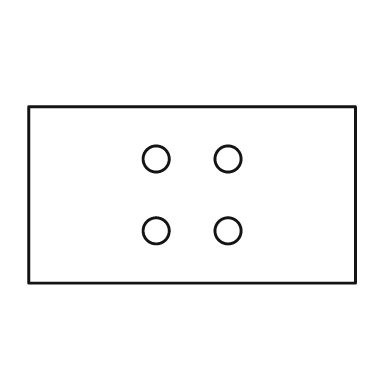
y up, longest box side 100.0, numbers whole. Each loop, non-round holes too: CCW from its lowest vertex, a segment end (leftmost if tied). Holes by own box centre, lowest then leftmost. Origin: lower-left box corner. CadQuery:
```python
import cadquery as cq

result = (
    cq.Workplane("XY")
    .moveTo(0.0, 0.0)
    .lineTo(100.0, 0.0)
    .lineTo(100.0, 54.0)
    .lineTo(0.0, 54.0)
    .close()
    .moveTo(39.0, 16.0)
    .circle(4.0)
    .moveTo(61.0, 16.0)
    .circle(4.0)
    .moveTo(39.0, 38.0)
    .circle(4.0)
    .moveTo(61.0, 38.0)
    .circle(4.0)
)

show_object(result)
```